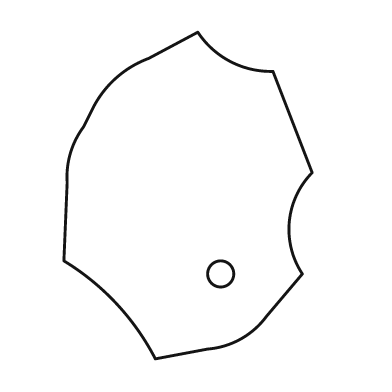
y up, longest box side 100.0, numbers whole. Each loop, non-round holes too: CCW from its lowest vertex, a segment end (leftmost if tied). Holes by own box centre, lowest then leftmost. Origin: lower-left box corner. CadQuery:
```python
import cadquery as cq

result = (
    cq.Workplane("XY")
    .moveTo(28.0, 0.0)
    .lineTo(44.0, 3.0)
    .threePointArc((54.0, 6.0), (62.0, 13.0))
    .lineTo(73.0, 26.0)
    .threePointArc((69.0, 42.0), (76.0, 57.0))
    .lineTo(64.0, 88.0)
    .threePointArc((51.0, 91.0), (41.0, 100.0))
    .lineTo(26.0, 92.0)
    .threePointArc((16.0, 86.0), (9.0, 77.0))
    .lineTo(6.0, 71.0)
    .threePointArc((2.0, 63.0), (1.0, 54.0))
    .lineTo(0.0, 30.0)
    .threePointArc((16.0, 17.0), (28.0, 0.0))
    .close()
    .moveTo(48.0, 26.0)
    .circle(4.0)
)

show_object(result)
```